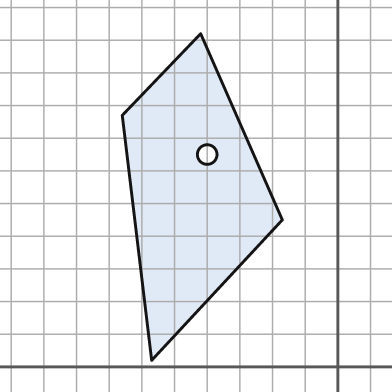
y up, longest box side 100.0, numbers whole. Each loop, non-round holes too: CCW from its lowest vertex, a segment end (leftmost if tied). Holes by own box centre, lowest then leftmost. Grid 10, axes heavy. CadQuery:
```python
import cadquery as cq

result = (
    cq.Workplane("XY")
    .moveTo(-57.0, 2.0)
    .lineTo(-17.0, 45.0)
    .lineTo(-42.0, 102.0)
    .lineTo(-66.0, 77.0)
    .close()
    .moveTo(-40.0, 65.0)
    .circle(3.0)
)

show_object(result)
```